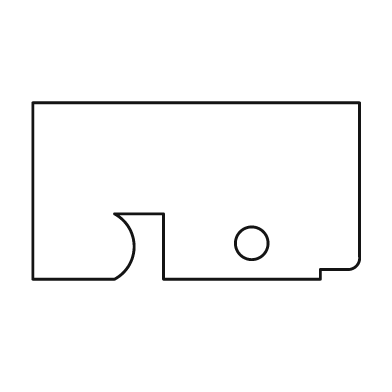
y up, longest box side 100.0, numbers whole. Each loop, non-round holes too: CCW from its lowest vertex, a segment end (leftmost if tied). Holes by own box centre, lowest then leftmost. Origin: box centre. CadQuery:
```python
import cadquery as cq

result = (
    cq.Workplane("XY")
    .moveTo(-50.0, -27.0)
    .lineTo(-25.0, -27.0)
    .threePointArc((-19.0, -17.0), (-25.0, -7.0))
    .lineTo(-10.0, -7.0)
    .lineTo(-10.0, -27.0)
    .lineTo(38.0, -27.0)
    .lineTo(38.0, -24.0)
    .lineTo(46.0, -24.0)
    .threePointArc((49.0, -23.0), (50.0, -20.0))
    .lineTo(50.0, 27.0)
    .lineTo(-50.0, 27.0)
    .close()
    .moveTo(17.0, -16.0)
    .circle(5.0)
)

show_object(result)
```